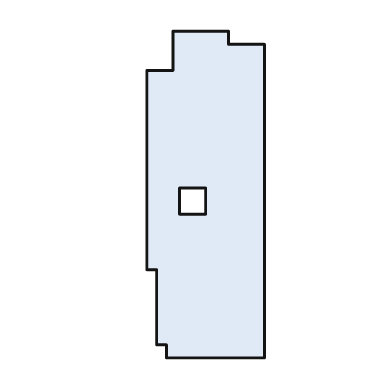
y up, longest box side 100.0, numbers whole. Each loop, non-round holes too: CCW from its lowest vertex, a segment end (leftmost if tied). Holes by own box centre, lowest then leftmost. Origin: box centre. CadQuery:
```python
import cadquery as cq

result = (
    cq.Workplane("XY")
    .moveTo(-12.0, -50.0)
    .lineTo(18.0, -50.0)
    .lineTo(18.0, 46.0)
    .lineTo(7.0, 46.0)
    .lineTo(7.0, 50.0)
    .lineTo(-10.0, 50.0)
    .lineTo(-10.0, 38.0)
    .lineTo(-18.0, 38.0)
    .lineTo(-18.0, -23.0)
    .lineTo(-15.0, -23.0)
    .lineTo(-15.0, -46.0)
    .lineTo(-12.0, -46.0)
    .close()
    .moveTo(-8.0, -6.0)
    .lineTo(0.0, -6.0)
    .lineTo(0.0, 2.0)
    .lineTo(-8.0, 2.0)
    .close()
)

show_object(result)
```